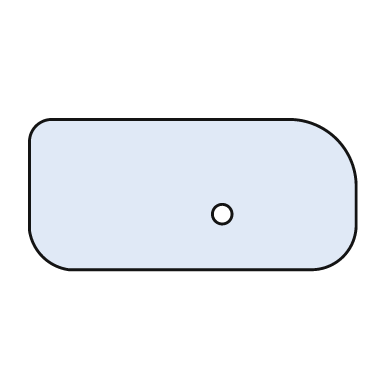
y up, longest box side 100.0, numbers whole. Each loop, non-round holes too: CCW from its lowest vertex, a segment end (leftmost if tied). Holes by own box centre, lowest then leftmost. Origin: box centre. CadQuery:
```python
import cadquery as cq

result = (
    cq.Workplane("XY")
    .moveTo(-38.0, -23.0)
    .lineTo(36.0, -23.0)
    .threePointArc((46.0, -19.0), (50.0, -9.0))
    .lineTo(50.0, 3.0)
    .threePointArc((44.0, 17.0), (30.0, 23.0))
    .lineTo(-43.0, 23.0)
    .threePointArc((-48.0, 21.0), (-50.0, 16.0))
    .lineTo(-50.0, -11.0)
    .threePointArc((-46.0, -19.0), (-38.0, -23.0))
    .close()
    .moveTo(9.0, -6.0)
    .circle(3.0)
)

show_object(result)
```